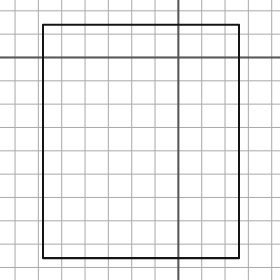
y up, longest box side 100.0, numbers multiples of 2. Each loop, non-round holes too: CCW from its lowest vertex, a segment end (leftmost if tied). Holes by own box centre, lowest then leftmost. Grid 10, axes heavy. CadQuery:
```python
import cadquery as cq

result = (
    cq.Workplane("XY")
    .moveTo(-58.0, -86.0)
    .lineTo(26.0, -86.0)
    .lineTo(26.0, 14.0)
    .lineTo(-58.0, 14.0)
    .close()
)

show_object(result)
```